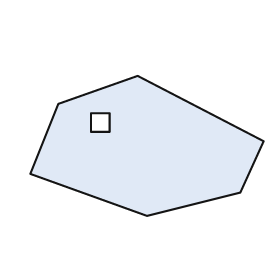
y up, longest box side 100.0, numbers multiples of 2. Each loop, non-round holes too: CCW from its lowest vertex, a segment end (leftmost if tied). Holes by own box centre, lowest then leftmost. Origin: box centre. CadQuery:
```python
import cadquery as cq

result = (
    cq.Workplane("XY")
    .moveTo(0.0, -30.0)
    .lineTo(40.0, -20.0)
    .lineTo(50.0, 2.0)
    .lineTo(-4.0, 30.0)
    .lineTo(-38.0, 18.0)
    .lineTo(-50.0, -12.0)
    .close()
    .moveTo(-24.0, 6.0)
    .lineTo(-16.0, 6.0)
    .lineTo(-16.0, 14.0)
    .lineTo(-24.0, 14.0)
    .close()
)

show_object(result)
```